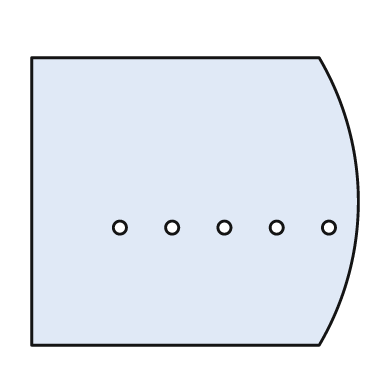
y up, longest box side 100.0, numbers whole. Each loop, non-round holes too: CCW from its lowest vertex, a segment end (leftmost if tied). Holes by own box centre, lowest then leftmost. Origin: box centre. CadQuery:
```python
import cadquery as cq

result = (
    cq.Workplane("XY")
    .moveTo(-50.0, -44.0)
    .lineTo(38.0, -44.0)
    .threePointArc((50.0, 0.0), (38.0, 44.0))
    .lineTo(-50.0, 44.0)
    .close()
    .moveTo(-23.0, -8.0)
    .circle(2.0)
    .moveTo(-7.0, -8.0)
    .circle(2.0)
    .moveTo(9.0, -8.0)
    .circle(2.0)
    .moveTo(25.0, -8.0)
    .circle(2.0)
    .moveTo(41.0, -8.0)
    .circle(2.0)
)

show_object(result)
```